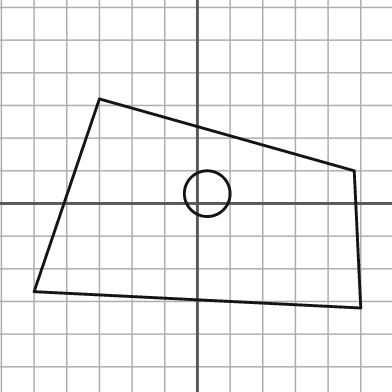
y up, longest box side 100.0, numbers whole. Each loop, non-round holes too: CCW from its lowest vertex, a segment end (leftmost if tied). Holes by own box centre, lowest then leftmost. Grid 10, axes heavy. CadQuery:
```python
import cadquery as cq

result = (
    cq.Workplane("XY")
    .moveTo(50.0, -32.0)
    .lineTo(48.0, 10.0)
    .lineTo(-30.0, 32.0)
    .lineTo(-50.0, -27.0)
    .close()
    .moveTo(3.0, 3.0)
    .circle(7.0)
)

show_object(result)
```